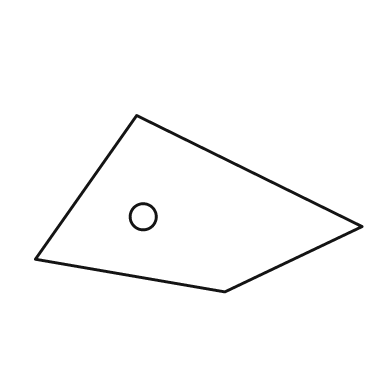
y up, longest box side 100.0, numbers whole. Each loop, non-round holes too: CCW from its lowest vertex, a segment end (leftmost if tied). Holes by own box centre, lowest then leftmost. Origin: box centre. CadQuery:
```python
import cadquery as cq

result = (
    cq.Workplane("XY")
    .moveTo(8.0, -27.0)
    .lineTo(50.0, -7.0)
    .lineTo(-19.0, 27.0)
    .lineTo(-50.0, -17.0)
    .close()
    .moveTo(-17.0, -4.0)
    .circle(4.0)
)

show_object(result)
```